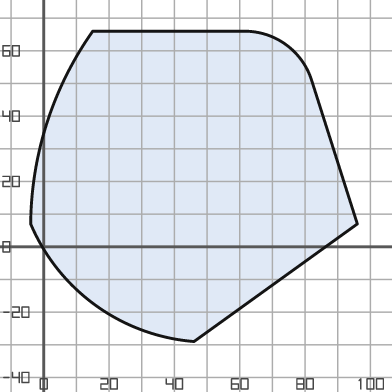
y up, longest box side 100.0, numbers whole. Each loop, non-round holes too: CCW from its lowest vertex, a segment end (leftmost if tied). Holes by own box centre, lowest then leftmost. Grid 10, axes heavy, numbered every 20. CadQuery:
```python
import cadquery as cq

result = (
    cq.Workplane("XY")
    .moveTo(46.0, -29.0)
    .lineTo(96.0, 7.0)
    .lineTo(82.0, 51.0)
    .threePointArc((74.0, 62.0), (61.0, 66.0))
    .lineTo(15.0, 66.0)
    .threePointArc((1.0, 38.0), (-4.0, 7.0))
    .threePointArc((16.0, -18.0), (46.0, -29.0))
    .close()
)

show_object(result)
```